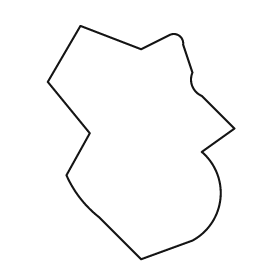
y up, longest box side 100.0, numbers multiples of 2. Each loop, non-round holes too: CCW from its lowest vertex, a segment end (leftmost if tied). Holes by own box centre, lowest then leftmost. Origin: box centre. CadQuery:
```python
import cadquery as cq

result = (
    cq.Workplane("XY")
    .moveTo(0.0, -50.0)
    .lineTo(22.0, -42.0)
    .threePointArc((34.0, -24.0), (26.0, -4.0))
    .lineTo(40.0, 6.0)
    .lineTo(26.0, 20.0)
    .threePointArc((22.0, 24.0), (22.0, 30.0))
    .lineTo(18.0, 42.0)
    .threePointArc((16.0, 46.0), (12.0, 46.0))
    .lineTo(0.0, 40.0)
    .lineTo(-26.0, 50.0)
    .lineTo(-40.0, 26.0)
    .lineTo(-22.0, 4.0)
    .lineTo(-32.0, -14.0)
    .threePointArc((-26.0, -24.0), (-18.0, -32.0))
    .close()
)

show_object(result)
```